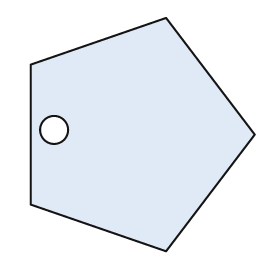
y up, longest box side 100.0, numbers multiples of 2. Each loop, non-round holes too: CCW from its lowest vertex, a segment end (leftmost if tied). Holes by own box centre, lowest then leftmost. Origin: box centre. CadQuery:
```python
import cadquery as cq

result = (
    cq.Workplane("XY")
    .moveTo(10.0, -50.0)
    .lineTo(48.0, 0.0)
    .lineTo(10.0, 50.0)
    .lineTo(-48.0, 30.0)
    .lineTo(-48.0, -30.0)
    .close()
    .moveTo(-38.0, 2.0)
    .circle(6.0)
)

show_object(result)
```